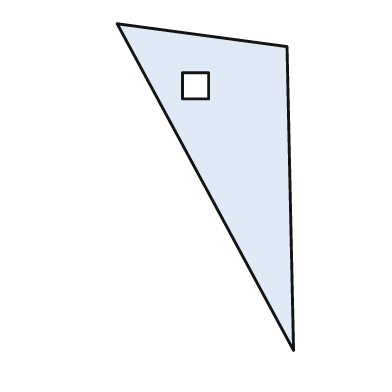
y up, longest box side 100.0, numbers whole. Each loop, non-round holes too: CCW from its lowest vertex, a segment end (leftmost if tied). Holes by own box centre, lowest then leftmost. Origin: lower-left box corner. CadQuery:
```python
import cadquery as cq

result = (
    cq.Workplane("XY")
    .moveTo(54.0, 0.0)
    .lineTo(52.0, 93.0)
    .lineTo(0.0, 100.0)
    .close()
    .moveTo(20.0, 77.0)
    .lineTo(28.0, 77.0)
    .lineTo(28.0, 85.0)
    .lineTo(20.0, 85.0)
    .close()
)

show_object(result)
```